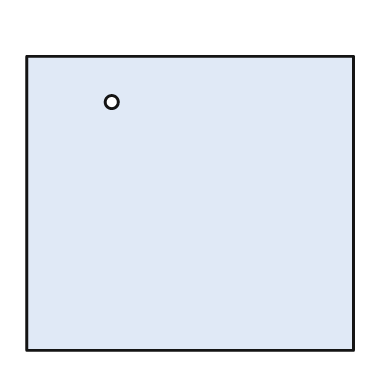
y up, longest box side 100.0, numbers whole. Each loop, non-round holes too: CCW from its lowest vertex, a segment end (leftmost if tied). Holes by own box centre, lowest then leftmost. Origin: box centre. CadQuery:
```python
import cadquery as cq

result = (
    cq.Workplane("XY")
    .moveTo(-50.0, -45.0)
    .lineTo(50.0, -45.0)
    .lineTo(50.0, 45.0)
    .lineTo(-50.0, 45.0)
    .close()
    .moveTo(-24.0, 31.0)
    .circle(2.0)
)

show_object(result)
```